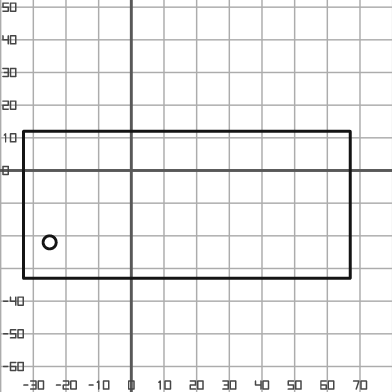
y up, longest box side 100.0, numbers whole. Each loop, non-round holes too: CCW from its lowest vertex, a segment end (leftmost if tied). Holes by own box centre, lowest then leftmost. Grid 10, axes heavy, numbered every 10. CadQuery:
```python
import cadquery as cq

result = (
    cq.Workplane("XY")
    .moveTo(-33.0, -33.0)
    .lineTo(67.0, -33.0)
    .lineTo(67.0, 12.0)
    .lineTo(-33.0, 12.0)
    .close()
    .moveTo(-25.0, -22.0)
    .circle(2.0)
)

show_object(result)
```